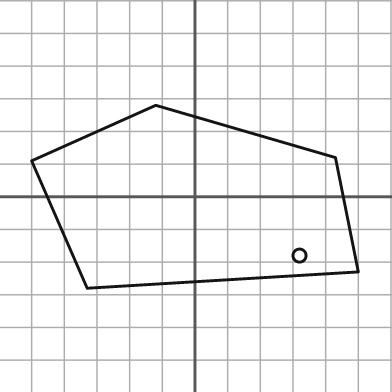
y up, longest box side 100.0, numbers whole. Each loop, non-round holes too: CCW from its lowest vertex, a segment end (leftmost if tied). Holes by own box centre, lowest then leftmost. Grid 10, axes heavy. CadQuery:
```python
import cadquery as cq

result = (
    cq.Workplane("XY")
    .moveTo(-33.0, -28.0)
    .lineTo(50.0, -23.0)
    .lineTo(43.0, 12.0)
    .lineTo(-12.0, 28.0)
    .lineTo(-50.0, 11.0)
    .close()
    .moveTo(32.0, -18.0)
    .circle(2.0)
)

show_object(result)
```